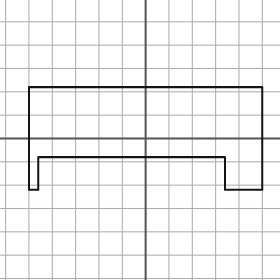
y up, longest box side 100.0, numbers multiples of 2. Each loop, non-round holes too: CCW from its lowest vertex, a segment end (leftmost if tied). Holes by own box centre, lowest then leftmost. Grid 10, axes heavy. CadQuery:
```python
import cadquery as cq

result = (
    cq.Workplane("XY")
    .moveTo(-50.0, -22.0)
    .lineTo(-46.0, -22.0)
    .lineTo(-46.0, -8.0)
    .lineTo(34.0, -8.0)
    .lineTo(34.0, -22.0)
    .lineTo(50.0, -22.0)
    .lineTo(50.0, 22.0)
    .lineTo(-50.0, 22.0)
    .close()
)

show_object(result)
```